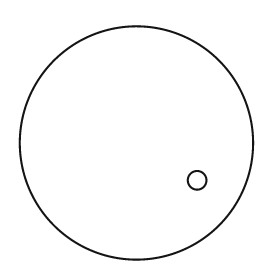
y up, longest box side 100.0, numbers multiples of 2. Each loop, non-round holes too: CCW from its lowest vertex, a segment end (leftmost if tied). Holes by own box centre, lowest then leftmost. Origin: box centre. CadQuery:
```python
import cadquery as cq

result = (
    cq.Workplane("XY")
    .moveTo(0.0, 0.0)
    .circle(50.0)
    .moveTo(26.0, -16.0)
    .circle(4.0)
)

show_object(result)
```